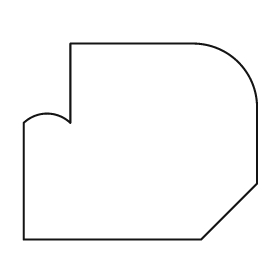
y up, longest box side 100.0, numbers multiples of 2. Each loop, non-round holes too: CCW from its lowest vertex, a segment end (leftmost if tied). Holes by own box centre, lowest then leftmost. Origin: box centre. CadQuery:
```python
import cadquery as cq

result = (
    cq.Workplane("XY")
    .moveTo(-50.0, -42.0)
    .lineTo(26.0, -42.0)
    .lineTo(50.0, -18.0)
    .lineTo(50.0, 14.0)
    .threePointArc((42.0, 34.0), (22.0, 42.0))
    .lineTo(-30.0, 42.0)
    .lineTo(-30.0, 8.0)
    .threePointArc((-40.0, 12.0), (-50.0, 8.0))
    .close()
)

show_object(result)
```